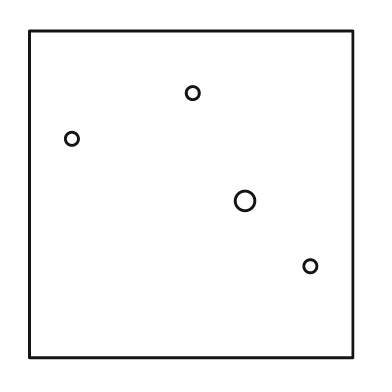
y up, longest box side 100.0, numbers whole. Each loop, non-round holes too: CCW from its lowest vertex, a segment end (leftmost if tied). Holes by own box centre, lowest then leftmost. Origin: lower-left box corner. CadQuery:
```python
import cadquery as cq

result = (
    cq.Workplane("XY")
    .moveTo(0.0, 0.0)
    .lineTo(99.0, 0.0)
    .lineTo(99.0, 100.0)
    .lineTo(0.0, 100.0)
    .close()
    .moveTo(86.0, 28.0)
    .circle(2.0)
    .moveTo(66.0, 48.0)
    .circle(3.0)
    .moveTo(13.0, 67.0)
    .circle(2.0)
    .moveTo(50.0, 81.0)
    .circle(2.0)
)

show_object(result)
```